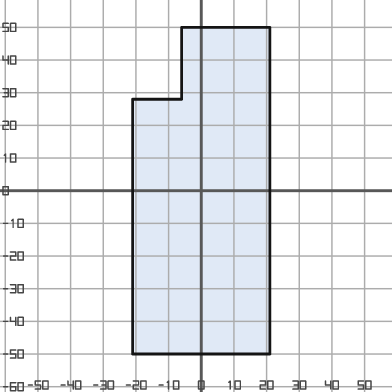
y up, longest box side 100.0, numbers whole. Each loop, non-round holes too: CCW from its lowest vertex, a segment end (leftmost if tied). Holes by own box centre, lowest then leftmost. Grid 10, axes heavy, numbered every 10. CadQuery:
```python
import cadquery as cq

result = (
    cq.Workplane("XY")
    .moveTo(-21.0, -50.0)
    .lineTo(21.0, -50.0)
    .lineTo(21.0, 50.0)
    .lineTo(-6.0, 50.0)
    .lineTo(-6.0, 28.0)
    .lineTo(-21.0, 28.0)
    .close()
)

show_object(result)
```